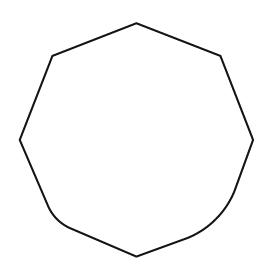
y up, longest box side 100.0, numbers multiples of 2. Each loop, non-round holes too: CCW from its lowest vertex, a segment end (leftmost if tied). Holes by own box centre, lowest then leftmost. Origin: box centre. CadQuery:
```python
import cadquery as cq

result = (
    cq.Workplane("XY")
    .moveTo(0.0, -50.0)
    .lineTo(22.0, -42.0)
    .threePointArc((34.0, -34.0), (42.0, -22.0))
    .lineTo(50.0, 0.0)
    .lineTo(36.0, 36.0)
    .lineTo(0.0, 50.0)
    .lineTo(-36.0, 36.0)
    .lineTo(-50.0, 0.0)
    .lineTo(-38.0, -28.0)
    .threePointArc((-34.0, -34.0), (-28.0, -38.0))
    .close()
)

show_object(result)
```